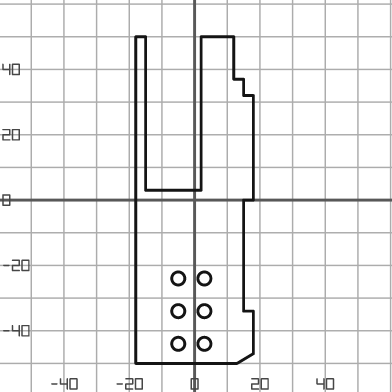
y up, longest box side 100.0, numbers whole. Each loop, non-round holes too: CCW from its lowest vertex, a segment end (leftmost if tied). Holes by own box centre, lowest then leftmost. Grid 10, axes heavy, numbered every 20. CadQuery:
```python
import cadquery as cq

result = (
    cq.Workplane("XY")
    .moveTo(-18.0, -50.0)
    .lineTo(13.0, -50.0)
    .lineTo(18.0, -47.0)
    .lineTo(18.0, -34.0)
    .lineTo(15.0, -34.0)
    .lineTo(15.0, 0.0)
    .lineTo(18.0, 0.0)
    .lineTo(18.0, 32.0)
    .lineTo(15.0, 32.0)
    .lineTo(15.0, 37.0)
    .lineTo(12.0, 37.0)
    .lineTo(12.0, 50.0)
    .lineTo(2.0, 50.0)
    .lineTo(2.0, 3.0)
    .lineTo(-15.0, 3.0)
    .lineTo(-15.0, 50.0)
    .lineTo(-18.0, 50.0)
    .close()
    .moveTo(-5.0, -44.0)
    .circle(2.0)
    .moveTo(3.0, -44.0)
    .circle(2.0)
    .moveTo(-5.0, -34.0)
    .circle(2.0)
    .moveTo(3.0, -34.0)
    .circle(2.0)
    .moveTo(-5.0, -24.0)
    .circle(2.0)
    .moveTo(3.0, -24.0)
    .circle(2.0)
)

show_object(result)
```